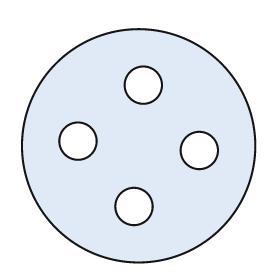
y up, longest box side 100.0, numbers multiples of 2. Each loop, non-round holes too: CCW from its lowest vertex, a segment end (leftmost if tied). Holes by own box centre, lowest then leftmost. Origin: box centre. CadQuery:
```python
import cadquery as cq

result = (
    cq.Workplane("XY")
    .moveTo(0.0, 0.0)
    .circle(50.0)
    .moveTo(-2.0, -26.0)
    .circle(8.0)
    .moveTo(26.0, -2.0)
    .circle(8.0)
    .moveTo(-26.0, 2.0)
    .circle(8.0)
    .moveTo(2.0, 26.0)
    .circle(8.0)
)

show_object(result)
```